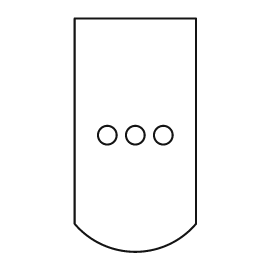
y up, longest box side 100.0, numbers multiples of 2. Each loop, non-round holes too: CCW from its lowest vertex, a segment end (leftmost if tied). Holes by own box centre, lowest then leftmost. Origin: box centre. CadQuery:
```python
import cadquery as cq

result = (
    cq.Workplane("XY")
    .moveTo(-26.0, -38.0)
    .threePointArc((0.0, -50.0), (26.0, -38.0))
    .lineTo(26.0, 50.0)
    .lineTo(-26.0, 50.0)
    .close()
    .moveTo(-12.0, 0.0)
    .circle(4.0)
    .moveTo(0.0, 0.0)
    .circle(4.0)
    .moveTo(12.0, 0.0)
    .circle(4.0)
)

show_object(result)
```